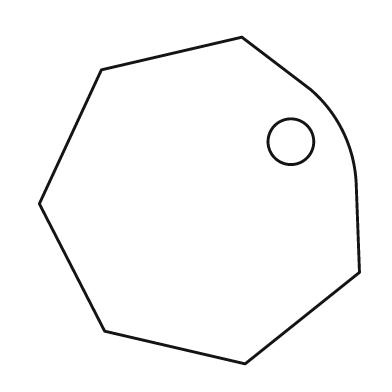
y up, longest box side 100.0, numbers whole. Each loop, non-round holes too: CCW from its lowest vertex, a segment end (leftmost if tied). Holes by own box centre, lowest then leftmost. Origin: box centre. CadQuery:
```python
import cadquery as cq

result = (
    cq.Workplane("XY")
    .moveTo(14.0, -50.0)
    .lineTo(49.0, -22.0)
    .lineTo(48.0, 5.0)
    .threePointArc((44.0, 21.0), (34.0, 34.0))
    .lineTo(13.0, 50.0)
    .lineTo(-30.0, 40.0)
    .lineTo(-49.0, -1.0)
    .lineTo(-29.0, -40.0)
    .close()
    .moveTo(28.0, 18.0)
    .circle(7.0)
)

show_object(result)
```